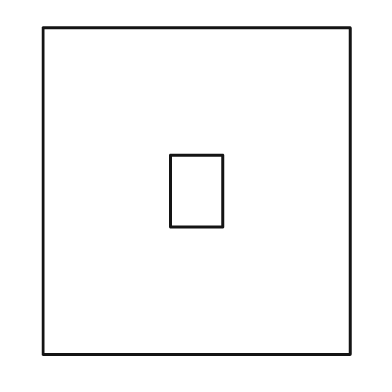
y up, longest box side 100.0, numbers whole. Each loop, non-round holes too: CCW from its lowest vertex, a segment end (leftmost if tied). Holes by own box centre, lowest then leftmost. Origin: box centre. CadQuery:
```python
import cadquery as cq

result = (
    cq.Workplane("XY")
    .moveTo(-47.0, -50.0)
    .lineTo(47.0, -50.0)
    .lineTo(47.0, 50.0)
    .lineTo(-47.0, 50.0)
    .close()
    .moveTo(-8.0, -11.0)
    .lineTo(8.0, -11.0)
    .lineTo(8.0, 11.0)
    .lineTo(-8.0, 11.0)
    .close()
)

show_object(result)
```